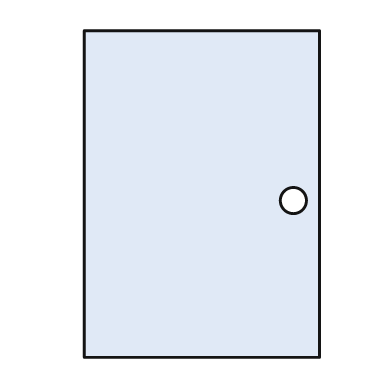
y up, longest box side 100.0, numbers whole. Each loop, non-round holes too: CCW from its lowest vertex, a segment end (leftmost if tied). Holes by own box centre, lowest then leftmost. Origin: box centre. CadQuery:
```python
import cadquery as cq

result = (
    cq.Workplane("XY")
    .moveTo(-36.0, -50.0)
    .lineTo(36.0, -50.0)
    .lineTo(36.0, 50.0)
    .lineTo(-36.0, 50.0)
    .close()
    .moveTo(28.0, -2.0)
    .circle(4.0)
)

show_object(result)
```